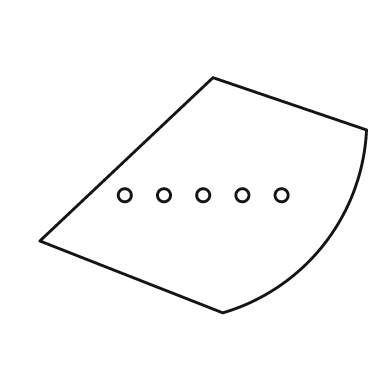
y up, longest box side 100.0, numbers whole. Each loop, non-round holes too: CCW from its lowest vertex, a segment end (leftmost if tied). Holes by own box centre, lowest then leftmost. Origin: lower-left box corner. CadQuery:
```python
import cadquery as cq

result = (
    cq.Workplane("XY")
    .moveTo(56.0, 0.0)
    .threePointArc((87.0, 21.0), (100.0, 56.0))
    .lineTo(53.0, 72.0)
    .lineTo(0.0, 22.0)
    .close()
    .moveTo(26.0, 36.0)
    .circle(2.0)
    .moveTo(38.0, 36.0)
    .circle(2.0)
    .moveTo(50.0, 36.0)
    .circle(2.0)
    .moveTo(62.0, 36.0)
    .circle(2.0)
    .moveTo(74.0, 36.0)
    .circle(2.0)
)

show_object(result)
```